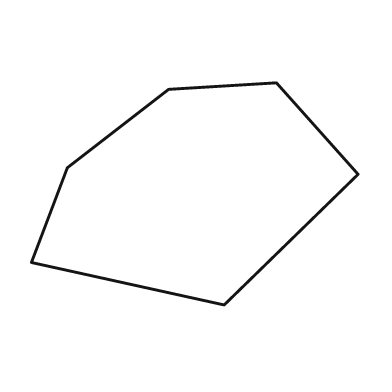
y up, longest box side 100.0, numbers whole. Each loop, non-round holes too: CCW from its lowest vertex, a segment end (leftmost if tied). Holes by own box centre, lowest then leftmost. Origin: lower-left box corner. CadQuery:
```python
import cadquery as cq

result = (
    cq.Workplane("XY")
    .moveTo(59.0, 0.0)
    .lineTo(100.0, 40.0)
    .lineTo(75.0, 68.0)
    .lineTo(42.0, 66.0)
    .lineTo(11.0, 42.0)
    .lineTo(0.0, 13.0)
    .close()
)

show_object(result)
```